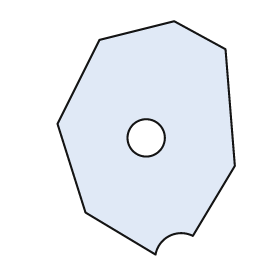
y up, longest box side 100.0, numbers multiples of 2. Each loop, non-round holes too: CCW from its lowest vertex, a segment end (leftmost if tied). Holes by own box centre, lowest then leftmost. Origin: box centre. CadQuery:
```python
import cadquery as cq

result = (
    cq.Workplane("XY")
    .moveTo(4.0, -50.0)
    .threePointArc((10.0, -42.0), (20.0, -42.0))
    .lineTo(38.0, -12.0)
    .lineTo(34.0, 38.0)
    .lineTo(12.0, 50.0)
    .lineTo(-20.0, 42.0)
    .lineTo(-38.0, 6.0)
    .lineTo(-26.0, -32.0)
    .close()
    .moveTo(0.0, 0.0)
    .circle(8.0)
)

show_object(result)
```